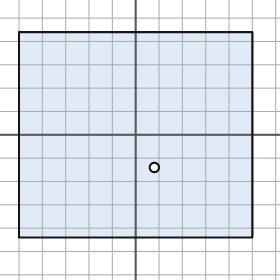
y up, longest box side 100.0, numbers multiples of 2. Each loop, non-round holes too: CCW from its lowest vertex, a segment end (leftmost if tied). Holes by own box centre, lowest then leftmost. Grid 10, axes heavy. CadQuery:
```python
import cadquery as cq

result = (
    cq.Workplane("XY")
    .moveTo(-50.0, -44.0)
    .lineTo(50.0, -44.0)
    .lineTo(50.0, 44.0)
    .lineTo(-50.0, 44.0)
    .close()
    .moveTo(8.0, -14.0)
    .circle(2.0)
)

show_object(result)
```